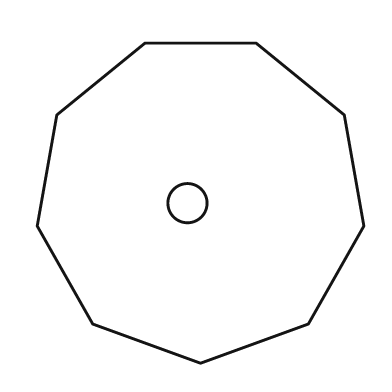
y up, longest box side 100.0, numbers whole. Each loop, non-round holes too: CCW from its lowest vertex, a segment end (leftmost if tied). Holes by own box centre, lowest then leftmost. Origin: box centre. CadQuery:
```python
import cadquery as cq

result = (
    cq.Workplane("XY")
    .moveTo(0.0, -49.0)
    .lineTo(33.0, -37.0)
    .lineTo(50.0, -7.0)
    .lineTo(44.0, 27.0)
    .lineTo(17.0, 49.0)
    .lineTo(-17.0, 49.0)
    .lineTo(-44.0, 27.0)
    .lineTo(-50.0, -7.0)
    .lineTo(-33.0, -37.0)
    .close()
    .moveTo(-4.0, 0.0)
    .circle(6.0)
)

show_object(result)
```